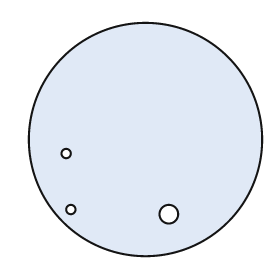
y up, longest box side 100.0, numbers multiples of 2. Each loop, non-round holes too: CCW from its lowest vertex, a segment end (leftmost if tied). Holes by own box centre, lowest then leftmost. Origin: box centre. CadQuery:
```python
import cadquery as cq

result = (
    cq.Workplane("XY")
    .moveTo(0.0, 0.0)
    .circle(50.0)
    .moveTo(10.0, -32.0)
    .circle(4.0)
    .moveTo(-32.0, -30.0)
    .circle(2.0)
    .moveTo(-34.0, -6.0)
    .circle(2.0)
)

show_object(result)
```